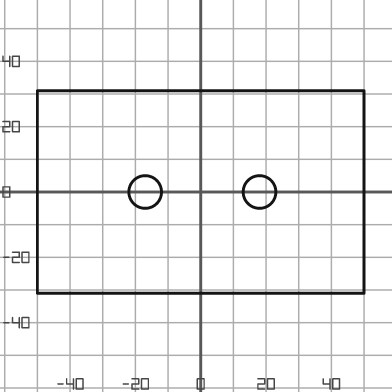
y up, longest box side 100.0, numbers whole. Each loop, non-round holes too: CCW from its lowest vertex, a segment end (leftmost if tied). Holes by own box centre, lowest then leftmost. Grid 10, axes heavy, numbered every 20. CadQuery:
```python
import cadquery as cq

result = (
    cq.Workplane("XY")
    .moveTo(-50.0, -31.0)
    .lineTo(50.0, -31.0)
    .lineTo(50.0, 31.0)
    .lineTo(-50.0, 31.0)
    .close()
    .moveTo(-17.0, 0.0)
    .circle(5.0)
    .moveTo(18.0, 0.0)
    .circle(5.0)
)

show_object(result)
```